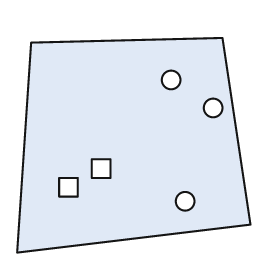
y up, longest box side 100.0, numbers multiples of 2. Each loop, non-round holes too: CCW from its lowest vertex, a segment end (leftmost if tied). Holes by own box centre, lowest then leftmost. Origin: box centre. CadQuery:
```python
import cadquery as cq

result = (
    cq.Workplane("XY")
    .moveTo(-50.0, -46.0)
    .lineTo(50.0, -34.0)
    .lineTo(38.0, 46.0)
    .lineTo(-44.0, 44.0)
    .close()
    .moveTo(22.0, -24.0)
    .circle(4.0)
    .moveTo(-32.0, -22.0)
    .lineTo(-24.0, -22.0)
    .lineTo(-24.0, -14.0)
    .lineTo(-32.0, -14.0)
    .close()
    .moveTo(-18.0, -14.0)
    .lineTo(-10.0, -14.0)
    .lineTo(-10.0, -6.0)
    .lineTo(-18.0, -6.0)
    .close()
    .moveTo(34.0, 16.0)
    .circle(4.0)
    .moveTo(16.0, 28.0)
    .circle(4.0)
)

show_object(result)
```